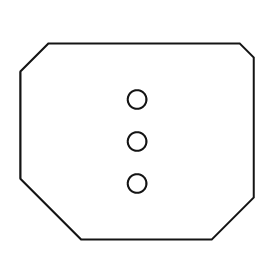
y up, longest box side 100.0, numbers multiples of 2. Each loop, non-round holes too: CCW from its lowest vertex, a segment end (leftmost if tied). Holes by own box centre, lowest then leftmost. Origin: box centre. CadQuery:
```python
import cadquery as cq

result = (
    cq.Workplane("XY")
    .moveTo(-24.0, -42.0)
    .lineTo(32.0, -42.0)
    .lineTo(50.0, -24.0)
    .lineTo(50.0, 36.0)
    .lineTo(44.0, 42.0)
    .lineTo(-38.0, 42.0)
    .lineTo(-50.0, 30.0)
    .lineTo(-50.0, -16.0)
    .close()
    .moveTo(0.0, -18.0)
    .circle(4.0)
    .moveTo(0.0, 0.0)
    .circle(4.0)
    .moveTo(0.0, 18.0)
    .circle(4.0)
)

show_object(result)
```